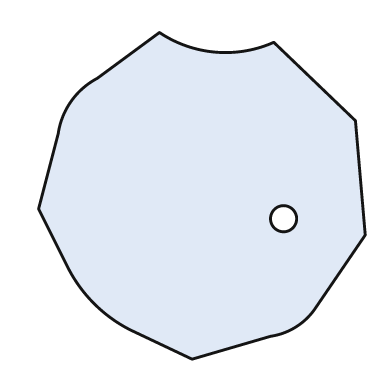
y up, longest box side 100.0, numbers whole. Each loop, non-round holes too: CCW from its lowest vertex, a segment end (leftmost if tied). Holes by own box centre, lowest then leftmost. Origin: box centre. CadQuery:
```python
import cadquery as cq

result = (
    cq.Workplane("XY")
    .moveTo(-3.0, -50.0)
    .lineTo(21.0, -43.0)
    .threePointArc((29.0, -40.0), (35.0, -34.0))
    .lineTo(50.0, -12.0)
    .lineTo(47.0, 23.0)
    .lineTo(22.0, 47.0)
    .threePointArc((4.0, 44.0), (-13.0, 50.0))
    .lineTo(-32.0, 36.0)
    .threePointArc((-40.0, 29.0), (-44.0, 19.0))
    .lineTo(-50.0, -4.0)
    .lineTo(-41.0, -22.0)
    .threePointArc((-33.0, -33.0), (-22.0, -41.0))
    .close()
    .moveTo(25.0, -7.0)
    .circle(4.0)
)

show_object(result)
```